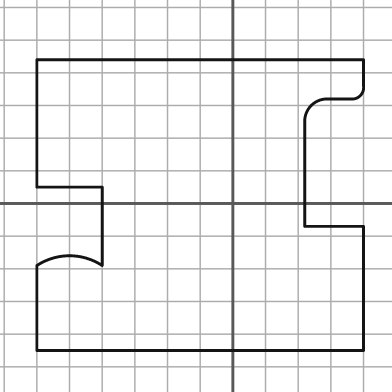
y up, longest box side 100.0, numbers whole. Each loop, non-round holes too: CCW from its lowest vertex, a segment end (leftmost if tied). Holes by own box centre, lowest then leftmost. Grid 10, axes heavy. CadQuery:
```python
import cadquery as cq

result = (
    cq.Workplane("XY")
    .moveTo(-60.0, -45.0)
    .lineTo(40.0, -45.0)
    .lineTo(40.0, -7.0)
    .lineTo(22.0, -7.0)
    .lineTo(22.0, 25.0)
    .threePointArc((24.0, 30.0), (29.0, 32.0))
    .lineTo(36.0, 32.0)
    .threePointArc((39.0, 33.0), (40.0, 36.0))
    .lineTo(40.0, 44.0)
    .lineTo(-60.0, 44.0)
    .lineTo(-60.0, 5.0)
    .lineTo(-40.0, 5.0)
    .lineTo(-40.0, -19.0)
    .threePointArc((-50.0, -16.0), (-60.0, -19.0))
    .close()
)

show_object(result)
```